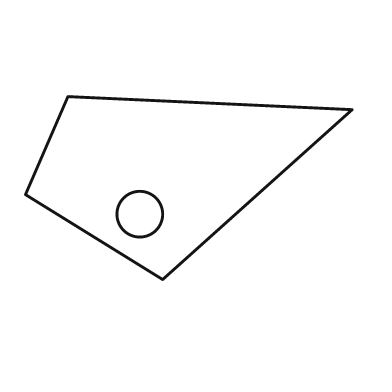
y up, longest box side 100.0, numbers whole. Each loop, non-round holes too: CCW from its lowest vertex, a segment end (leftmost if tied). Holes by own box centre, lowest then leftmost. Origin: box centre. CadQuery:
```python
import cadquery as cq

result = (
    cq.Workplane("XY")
    .moveTo(-8.0, -28.0)
    .lineTo(50.0, 24.0)
    .lineTo(-37.0, 28.0)
    .lineTo(-50.0, -2.0)
    .close()
    .moveTo(-15.0, -8.0)
    .circle(7.0)
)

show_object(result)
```